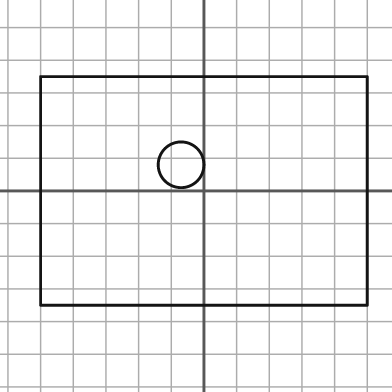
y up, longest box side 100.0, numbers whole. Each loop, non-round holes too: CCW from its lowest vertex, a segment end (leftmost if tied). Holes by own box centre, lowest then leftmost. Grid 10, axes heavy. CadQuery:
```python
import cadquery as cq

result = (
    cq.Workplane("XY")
    .moveTo(-50.0, -35.0)
    .lineTo(50.0, -35.0)
    .lineTo(50.0, 35.0)
    .lineTo(-50.0, 35.0)
    .close()
    .moveTo(-7.0, 8.0)
    .circle(7.0)
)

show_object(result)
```